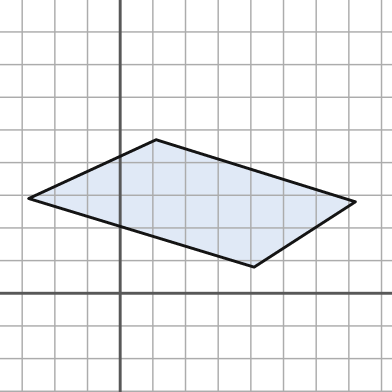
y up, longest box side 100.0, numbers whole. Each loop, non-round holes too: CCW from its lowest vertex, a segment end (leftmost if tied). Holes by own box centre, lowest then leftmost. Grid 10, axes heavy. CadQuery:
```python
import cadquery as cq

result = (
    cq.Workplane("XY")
    .moveTo(41.0, 8.0)
    .lineTo(72.0, 28.0)
    .lineTo(11.0, 47.0)
    .lineTo(-28.0, 29.0)
    .close()
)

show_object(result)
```